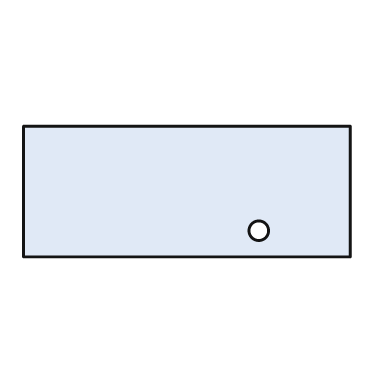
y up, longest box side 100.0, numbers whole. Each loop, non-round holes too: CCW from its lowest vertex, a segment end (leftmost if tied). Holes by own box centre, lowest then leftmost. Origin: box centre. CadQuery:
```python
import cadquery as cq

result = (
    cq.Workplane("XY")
    .moveTo(-50.0, -20.0)
    .lineTo(50.0, -20.0)
    .lineTo(50.0, 20.0)
    .lineTo(-50.0, 20.0)
    .close()
    .moveTo(22.0, -12.0)
    .circle(3.0)
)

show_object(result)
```